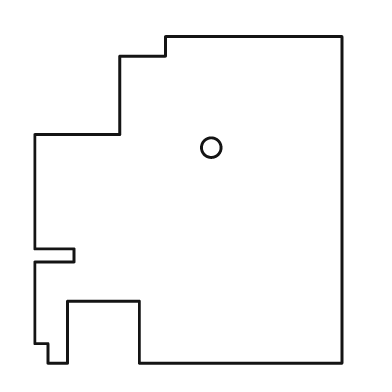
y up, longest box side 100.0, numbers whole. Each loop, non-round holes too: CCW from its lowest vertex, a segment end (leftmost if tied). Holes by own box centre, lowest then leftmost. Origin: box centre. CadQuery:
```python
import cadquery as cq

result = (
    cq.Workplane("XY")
    .moveTo(-43.0, -50.0)
    .lineTo(-37.0, -50.0)
    .lineTo(-37.0, -31.0)
    .lineTo(-15.0, -31.0)
    .lineTo(-15.0, -50.0)
    .lineTo(47.0, -50.0)
    .lineTo(47.0, 50.0)
    .lineTo(-7.0, 50.0)
    .lineTo(-7.0, 44.0)
    .lineTo(-21.0, 44.0)
    .lineTo(-21.0, 20.0)
    .lineTo(-47.0, 20.0)
    .lineTo(-47.0, -15.0)
    .lineTo(-35.0, -15.0)
    .lineTo(-35.0, -19.0)
    .lineTo(-47.0, -19.0)
    .lineTo(-47.0, -44.0)
    .lineTo(-43.0, -44.0)
    .close()
    .moveTo(7.0, 16.0)
    .circle(3.0)
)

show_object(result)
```